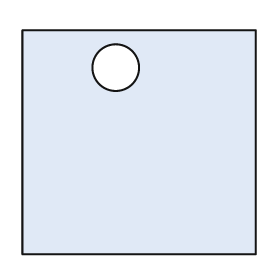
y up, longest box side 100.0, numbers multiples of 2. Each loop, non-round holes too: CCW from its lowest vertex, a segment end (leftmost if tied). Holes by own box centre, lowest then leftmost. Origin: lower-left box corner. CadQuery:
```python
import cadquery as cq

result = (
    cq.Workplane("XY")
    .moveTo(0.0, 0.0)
    .lineTo(100.0, 0.0)
    .lineTo(100.0, 96.0)
    .lineTo(0.0, 96.0)
    .close()
    .moveTo(40.0, 80.0)
    .circle(10.0)
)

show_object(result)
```